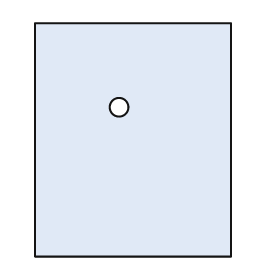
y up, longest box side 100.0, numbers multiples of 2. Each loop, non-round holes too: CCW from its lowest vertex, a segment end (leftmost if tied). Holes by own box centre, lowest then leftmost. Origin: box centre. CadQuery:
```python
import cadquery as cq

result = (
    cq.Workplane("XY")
    .moveTo(-42.0, -50.0)
    .lineTo(42.0, -50.0)
    .lineTo(42.0, 50.0)
    .lineTo(-42.0, 50.0)
    .close()
    .moveTo(-6.0, 14.0)
    .circle(4.0)
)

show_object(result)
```